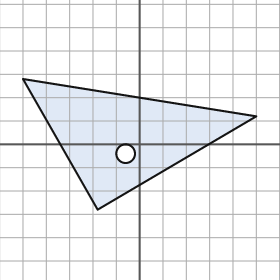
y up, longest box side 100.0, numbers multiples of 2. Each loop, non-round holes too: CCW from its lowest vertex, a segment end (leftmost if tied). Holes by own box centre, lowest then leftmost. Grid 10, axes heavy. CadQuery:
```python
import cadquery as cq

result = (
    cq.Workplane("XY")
    .moveTo(-18.0, -28.0)
    .lineTo(50.0, 12.0)
    .lineTo(-50.0, 28.0)
    .close()
    .moveTo(-6.0, -4.0)
    .circle(4.0)
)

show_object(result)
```